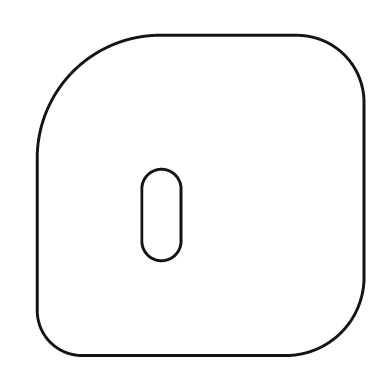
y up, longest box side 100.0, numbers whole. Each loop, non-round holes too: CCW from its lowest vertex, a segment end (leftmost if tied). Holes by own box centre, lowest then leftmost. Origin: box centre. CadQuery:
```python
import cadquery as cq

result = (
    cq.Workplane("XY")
    .moveTo(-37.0, -49.0)
    .lineTo(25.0, -49.0)
    .threePointArc((43.0, -42.0), (50.0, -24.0))
    .lineTo(50.0, 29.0)
    .threePointArc((44.0, 43.0), (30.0, 49.0))
    .lineTo(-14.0, 49.0)
    .threePointArc((-39.0, 38.0), (-50.0, 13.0))
    .lineTo(-50.0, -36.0)
    .threePointArc((-46.0, -45.0), (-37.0, -49.0))
    .close()
    .moveTo(-18.0, -14.0)
    .threePointArc((-12.0, -20.0), (-6.0, -14.0))
    .lineTo(-6.0, 2.0)
    .threePointArc((-12.0, 8.0), (-18.0, 2.0))
    .close()
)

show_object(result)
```